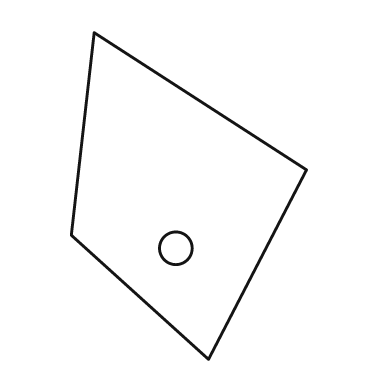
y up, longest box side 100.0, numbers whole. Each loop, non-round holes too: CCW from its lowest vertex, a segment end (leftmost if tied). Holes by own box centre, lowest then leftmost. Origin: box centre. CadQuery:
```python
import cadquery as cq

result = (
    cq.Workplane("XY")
    .moveTo(6.0, -50.0)
    .lineTo(36.0, 8.0)
    .lineTo(-29.0, 50.0)
    .lineTo(-36.0, -12.0)
    .close()
    .moveTo(-4.0, -16.0)
    .circle(5.0)
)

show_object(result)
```